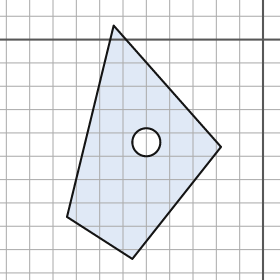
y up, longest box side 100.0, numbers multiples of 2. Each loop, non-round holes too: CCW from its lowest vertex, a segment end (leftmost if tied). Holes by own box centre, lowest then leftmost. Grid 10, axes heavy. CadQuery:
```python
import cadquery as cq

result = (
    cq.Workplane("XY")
    .moveTo(-56.0, -94.0)
    .lineTo(-18.0, -46.0)
    .lineTo(-64.0, 6.0)
    .lineTo(-84.0, -76.0)
    .close()
    .moveTo(-50.0, -44.0)
    .circle(6.0)
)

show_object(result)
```